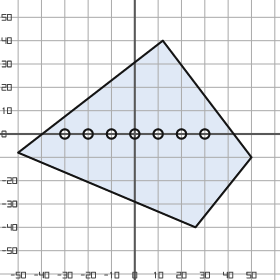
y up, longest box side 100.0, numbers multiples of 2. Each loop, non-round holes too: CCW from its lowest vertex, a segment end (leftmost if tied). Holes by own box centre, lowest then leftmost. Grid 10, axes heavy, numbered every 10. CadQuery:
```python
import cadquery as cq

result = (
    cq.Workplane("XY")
    .moveTo(26.0, -40.0)
    .lineTo(50.0, -10.0)
    .lineTo(12.0, 40.0)
    .lineTo(-50.0, -8.0)
    .close()
    .moveTo(-30.0, 0.0)
    .circle(2.0)
    .moveTo(-20.0, 0.0)
    .circle(2.0)
    .moveTo(-10.0, 0.0)
    .circle(2.0)
    .moveTo(0.0, 0.0)
    .circle(2.0)
    .moveTo(10.0, 0.0)
    .circle(2.0)
    .moveTo(20.0, 0.0)
    .circle(2.0)
    .moveTo(30.0, 0.0)
    .circle(2.0)
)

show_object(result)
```